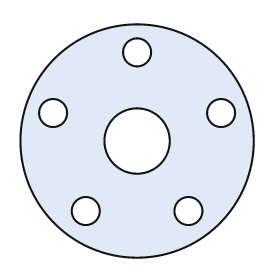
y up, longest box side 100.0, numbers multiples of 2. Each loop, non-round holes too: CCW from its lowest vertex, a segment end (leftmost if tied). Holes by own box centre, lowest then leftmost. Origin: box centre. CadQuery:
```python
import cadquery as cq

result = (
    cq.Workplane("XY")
    .moveTo(0.0, 0.0)
    .circle(50.0)
    .moveTo(-22.0, -30.0)
    .circle(6.0)
    .moveTo(22.0, -30.0)
    .circle(6.0)
    .moveTo(0.0, 0.0)
    .circle(14.0)
    .moveTo(-36.0, 12.0)
    .circle(6.0)
    .moveTo(36.0, 12.0)
    .circle(6.0)
    .moveTo(0.0, 38.0)
    .circle(6.0)
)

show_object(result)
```